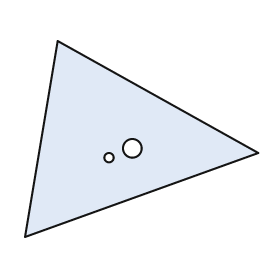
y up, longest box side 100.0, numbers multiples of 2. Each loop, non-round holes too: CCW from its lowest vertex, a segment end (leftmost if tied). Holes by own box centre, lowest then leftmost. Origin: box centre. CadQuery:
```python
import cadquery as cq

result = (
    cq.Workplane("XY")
    .moveTo(-50.0, -42.0)
    .lineTo(50.0, -6.0)
    .lineTo(-36.0, 42.0)
    .close()
    .moveTo(-14.0, -8.0)
    .circle(2.0)
    .moveTo(-4.0, -4.0)
    .circle(4.0)
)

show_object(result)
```